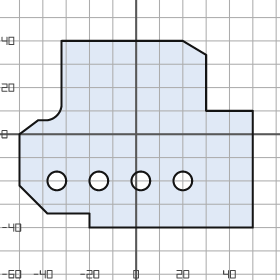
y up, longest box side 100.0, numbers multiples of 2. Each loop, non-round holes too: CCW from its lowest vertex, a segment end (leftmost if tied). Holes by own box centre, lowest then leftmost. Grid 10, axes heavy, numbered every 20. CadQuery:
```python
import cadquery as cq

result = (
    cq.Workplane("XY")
    .moveTo(-20.0, -40.0)
    .lineTo(50.0, -40.0)
    .lineTo(50.0, 10.0)
    .lineTo(30.0, 10.0)
    .lineTo(30.0, 34.0)
    .lineTo(20.0, 40.0)
    .lineTo(-32.0, 40.0)
    .lineTo(-32.0, 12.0)
    .threePointArc((-34.0, 8.0), (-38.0, 6.0))
    .lineTo(-42.0, 6.0)
    .lineTo(-50.0, 0.0)
    .lineTo(-50.0, -22.0)
    .lineTo(-38.0, -34.0)
    .lineTo(-20.0, -34.0)
    .close()
    .moveTo(-34.0, -20.0)
    .circle(4.0)
    .moveTo(-16.0, -20.0)
    .circle(4.0)
    .moveTo(2.0, -20.0)
    .circle(4.0)
    .moveTo(20.0, -20.0)
    .circle(4.0)
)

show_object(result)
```